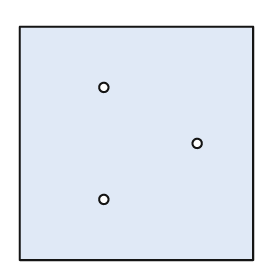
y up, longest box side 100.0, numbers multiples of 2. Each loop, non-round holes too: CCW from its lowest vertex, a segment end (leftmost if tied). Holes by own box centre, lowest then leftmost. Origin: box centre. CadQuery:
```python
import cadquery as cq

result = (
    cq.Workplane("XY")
    .moveTo(-50.0, -50.0)
    .lineTo(50.0, -50.0)
    .lineTo(50.0, 50.0)
    .lineTo(-50.0, 50.0)
    .close()
    .moveTo(-14.0, -24.0)
    .circle(2.0)
    .moveTo(26.0, 0.0)
    .circle(2.0)
    .moveTo(-14.0, 24.0)
    .circle(2.0)
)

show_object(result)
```